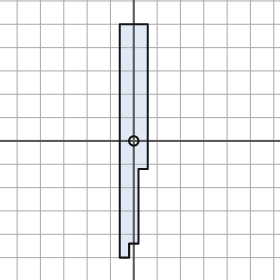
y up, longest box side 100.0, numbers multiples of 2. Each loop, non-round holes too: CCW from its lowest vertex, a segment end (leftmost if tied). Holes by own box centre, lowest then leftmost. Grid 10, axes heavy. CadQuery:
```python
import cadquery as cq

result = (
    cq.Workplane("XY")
    .moveTo(-6.0, -50.0)
    .lineTo(-2.0, -50.0)
    .lineTo(-2.0, -44.0)
    .lineTo(2.0, -44.0)
    .lineTo(2.0, -12.0)
    .lineTo(6.0, -12.0)
    .lineTo(6.0, 50.0)
    .lineTo(-6.0, 50.0)
    .close()
    .moveTo(0.0, 0.0)
    .circle(2.0)
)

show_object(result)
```